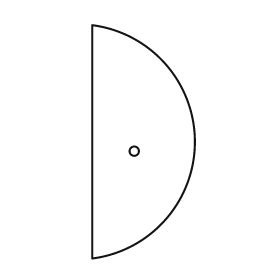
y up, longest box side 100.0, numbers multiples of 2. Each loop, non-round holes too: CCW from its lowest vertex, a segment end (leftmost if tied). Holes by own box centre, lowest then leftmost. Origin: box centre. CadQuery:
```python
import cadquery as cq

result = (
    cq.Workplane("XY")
    .moveTo(-22.0, -50.0)
    .threePointArc((22.0, 0.0), (-22.0, 50.0))
    .close()
    .moveTo(-4.0, -4.0)
    .circle(2.0)
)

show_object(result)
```